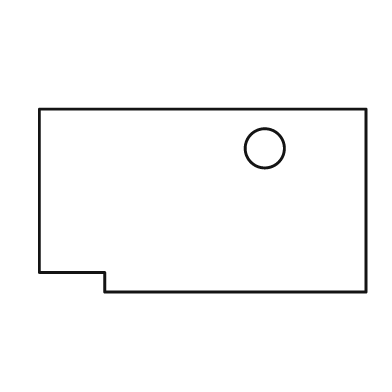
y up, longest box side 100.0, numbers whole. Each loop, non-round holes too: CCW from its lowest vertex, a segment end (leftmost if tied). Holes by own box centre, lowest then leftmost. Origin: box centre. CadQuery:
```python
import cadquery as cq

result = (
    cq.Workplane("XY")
    .moveTo(-30.0, -28.0)
    .lineTo(50.0, -28.0)
    .lineTo(50.0, 28.0)
    .lineTo(-50.0, 28.0)
    .lineTo(-50.0, -22.0)
    .lineTo(-30.0, -22.0)
    .close()
    .moveTo(19.0, 16.0)
    .circle(6.0)
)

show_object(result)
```